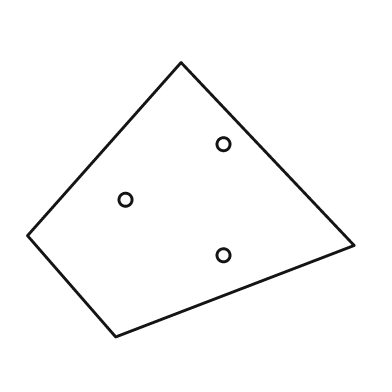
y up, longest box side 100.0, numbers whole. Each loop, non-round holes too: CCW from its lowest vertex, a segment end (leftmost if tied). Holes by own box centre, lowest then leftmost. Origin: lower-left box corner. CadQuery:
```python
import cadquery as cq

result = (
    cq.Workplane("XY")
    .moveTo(27.0, 0.0)
    .lineTo(100.0, 28.0)
    .lineTo(47.0, 84.0)
    .lineTo(0.0, 31.0)
    .close()
    .moveTo(60.0, 25.0)
    .circle(2.0)
    .moveTo(30.0, 42.0)
    .circle(2.0)
    .moveTo(60.0, 59.0)
    .circle(2.0)
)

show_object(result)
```